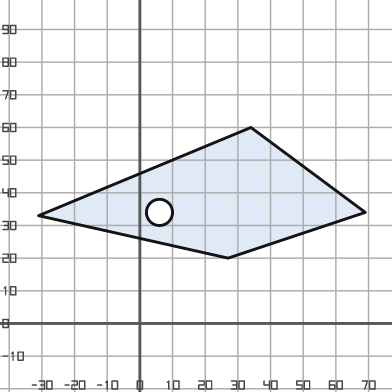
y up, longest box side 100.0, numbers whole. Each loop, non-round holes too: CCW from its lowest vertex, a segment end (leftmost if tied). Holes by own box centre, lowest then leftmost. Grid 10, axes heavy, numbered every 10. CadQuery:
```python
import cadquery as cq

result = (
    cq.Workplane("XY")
    .moveTo(27.0, 20.0)
    .lineTo(69.0, 34.0)
    .lineTo(34.0, 60.0)
    .lineTo(-31.0, 33.0)
    .close()
    .moveTo(6.0, 34.0)
    .circle(4.0)
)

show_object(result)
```